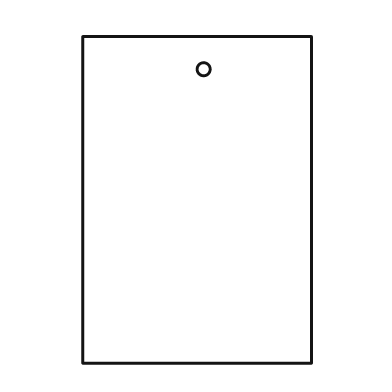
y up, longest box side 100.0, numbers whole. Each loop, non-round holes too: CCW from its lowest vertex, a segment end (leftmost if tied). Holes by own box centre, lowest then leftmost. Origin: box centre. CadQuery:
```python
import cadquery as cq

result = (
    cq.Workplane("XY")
    .moveTo(-35.0, -50.0)
    .lineTo(35.0, -50.0)
    .lineTo(35.0, 50.0)
    .lineTo(-35.0, 50.0)
    .close()
    .moveTo(2.0, 40.0)
    .circle(2.0)
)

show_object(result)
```